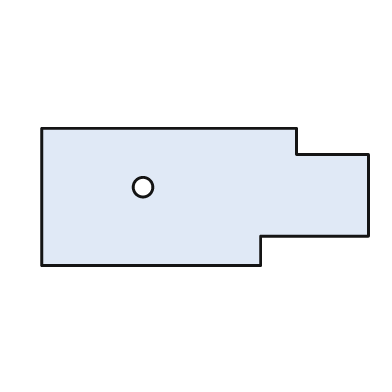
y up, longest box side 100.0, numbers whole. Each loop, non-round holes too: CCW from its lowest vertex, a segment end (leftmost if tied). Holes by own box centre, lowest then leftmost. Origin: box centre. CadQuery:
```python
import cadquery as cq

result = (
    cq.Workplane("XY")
    .moveTo(-50.0, -21.0)
    .lineTo(17.0, -21.0)
    .lineTo(17.0, -12.0)
    .lineTo(50.0, -12.0)
    .lineTo(50.0, 13.0)
    .lineTo(28.0, 13.0)
    .lineTo(28.0, 21.0)
    .lineTo(-50.0, 21.0)
    .close()
    .moveTo(-19.0, 3.0)
    .circle(3.0)
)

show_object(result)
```